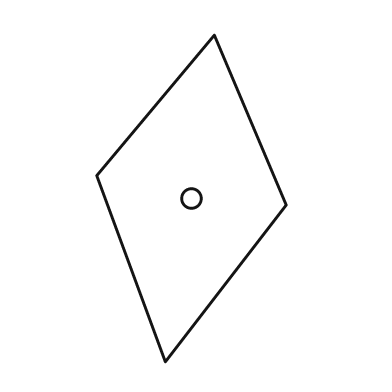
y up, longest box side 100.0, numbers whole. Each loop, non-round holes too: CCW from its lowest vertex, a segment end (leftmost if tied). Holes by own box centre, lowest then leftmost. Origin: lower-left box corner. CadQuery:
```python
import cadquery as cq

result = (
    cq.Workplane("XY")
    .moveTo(21.0, 0.0)
    .lineTo(58.0, 48.0)
    .lineTo(36.0, 100.0)
    .lineTo(0.0, 57.0)
    .close()
    .moveTo(29.0, 50.0)
    .circle(3.0)
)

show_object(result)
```